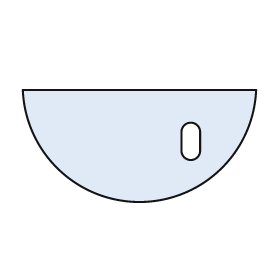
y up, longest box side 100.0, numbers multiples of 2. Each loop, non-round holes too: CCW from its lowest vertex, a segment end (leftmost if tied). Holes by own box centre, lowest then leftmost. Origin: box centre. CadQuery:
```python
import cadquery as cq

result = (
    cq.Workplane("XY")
    .moveTo(-50.0, 24.0)
    .threePointArc((0.0, -24.0), (50.0, 24.0))
    .close()
    .moveTo(18.0, -2.0)
    .threePointArc((22.0, -6.0), (26.0, -2.0))
    .lineTo(26.0, 6.0)
    .threePointArc((22.0, 10.0), (18.0, 6.0))
    .close()
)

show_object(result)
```